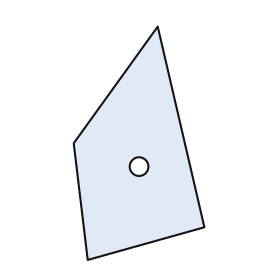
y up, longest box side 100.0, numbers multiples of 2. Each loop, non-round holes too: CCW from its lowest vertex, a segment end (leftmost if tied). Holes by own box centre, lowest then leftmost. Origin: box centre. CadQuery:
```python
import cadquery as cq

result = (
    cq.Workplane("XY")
    .moveTo(-22.0, -50.0)
    .lineTo(28.0, -36.0)
    .lineTo(8.0, 50.0)
    .lineTo(-28.0, 0.0)
    .close()
    .moveTo(0.0, -10.0)
    .circle(4.0)
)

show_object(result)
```